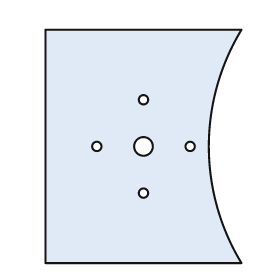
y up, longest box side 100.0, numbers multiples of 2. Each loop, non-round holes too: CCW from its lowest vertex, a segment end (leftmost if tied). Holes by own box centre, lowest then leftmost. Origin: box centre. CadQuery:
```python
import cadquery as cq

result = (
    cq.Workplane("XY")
    .moveTo(-42.0, -50.0)
    .lineTo(42.0, -50.0)
    .threePointArc((28.0, 0.0), (42.0, 50.0))
    .lineTo(-42.0, 50.0)
    .close()
    .moveTo(0.0, -20.0)
    .circle(2.0)
    .moveTo(-20.0, 0.0)
    .circle(2.0)
    .moveTo(0.0, 0.0)
    .circle(4.0)
    .moveTo(20.0, 0.0)
    .circle(2.0)
    .moveTo(0.0, 20.0)
    .circle(2.0)
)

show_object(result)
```